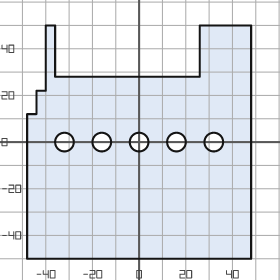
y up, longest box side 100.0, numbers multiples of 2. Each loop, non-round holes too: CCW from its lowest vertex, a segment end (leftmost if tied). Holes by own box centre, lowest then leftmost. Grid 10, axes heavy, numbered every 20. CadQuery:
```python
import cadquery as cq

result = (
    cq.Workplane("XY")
    .moveTo(-48.0, -50.0)
    .lineTo(48.0, -50.0)
    .lineTo(48.0, 50.0)
    .lineTo(26.0, 50.0)
    .lineTo(26.0, 28.0)
    .lineTo(-36.0, 28.0)
    .lineTo(-36.0, 50.0)
    .lineTo(-40.0, 50.0)
    .lineTo(-40.0, 22.0)
    .lineTo(-44.0, 22.0)
    .lineTo(-44.0, 12.0)
    .lineTo(-48.0, 12.0)
    .close()
    .moveTo(-32.0, 0.0)
    .circle(4.0)
    .moveTo(-16.0, 0.0)
    .circle(4.0)
    .moveTo(0.0, 0.0)
    .circle(4.0)
    .moveTo(16.0, 0.0)
    .circle(4.0)
    .moveTo(32.0, 0.0)
    .circle(4.0)
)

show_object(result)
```